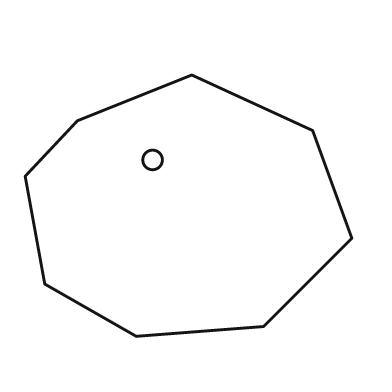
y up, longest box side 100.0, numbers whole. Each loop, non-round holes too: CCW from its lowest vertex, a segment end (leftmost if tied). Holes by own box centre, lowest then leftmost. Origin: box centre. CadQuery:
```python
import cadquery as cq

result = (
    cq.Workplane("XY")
    .moveTo(-16.0, -40.0)
    .lineTo(23.0, -37.0)
    .lineTo(50.0, -10.0)
    .lineTo(38.0, 23.0)
    .lineTo(1.0, 40.0)
    .lineTo(-34.0, 26.0)
    .lineTo(-50.0, 9.0)
    .lineTo(-44.0, -24.0)
    .close()
    .moveTo(-11.0, 14.0)
    .circle(3.0)
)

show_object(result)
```